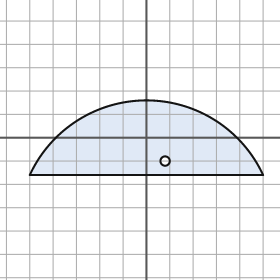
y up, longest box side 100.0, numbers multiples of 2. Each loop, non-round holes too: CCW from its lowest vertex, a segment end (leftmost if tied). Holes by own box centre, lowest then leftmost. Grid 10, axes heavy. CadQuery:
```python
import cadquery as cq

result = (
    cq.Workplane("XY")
    .moveTo(-50.0, -16.0)
    .lineTo(50.0, -16.0)
    .threePointArc((0.0, 16.0), (-50.0, -16.0))
    .close()
    .moveTo(8.0, -10.0)
    .circle(2.0)
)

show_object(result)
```